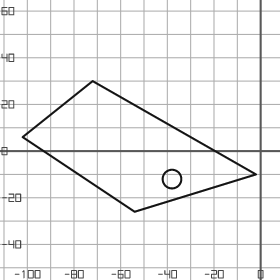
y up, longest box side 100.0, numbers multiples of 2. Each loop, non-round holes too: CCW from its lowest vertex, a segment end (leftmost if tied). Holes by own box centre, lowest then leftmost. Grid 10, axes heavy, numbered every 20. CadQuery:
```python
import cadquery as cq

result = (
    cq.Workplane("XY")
    .moveTo(-54.0, -26.0)
    .lineTo(-2.0, -10.0)
    .lineTo(-72.0, 30.0)
    .lineTo(-102.0, 6.0)
    .close()
    .moveTo(-38.0, -12.0)
    .circle(4.0)
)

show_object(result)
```